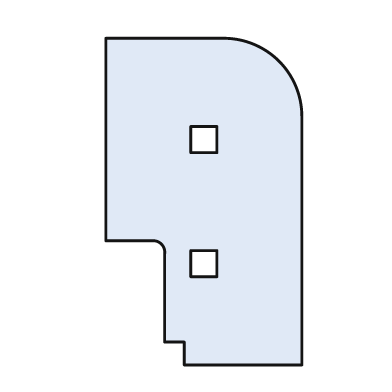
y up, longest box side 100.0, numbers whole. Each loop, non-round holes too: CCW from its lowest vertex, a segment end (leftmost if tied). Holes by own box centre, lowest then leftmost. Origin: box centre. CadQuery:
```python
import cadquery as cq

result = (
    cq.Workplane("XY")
    .moveTo(-6.0, -50.0)
    .lineTo(30.0, -50.0)
    .lineTo(30.0, 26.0)
    .threePointArc((23.0, 43.0), (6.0, 50.0))
    .lineTo(-30.0, 50.0)
    .lineTo(-30.0, -12.0)
    .lineTo(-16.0, -12.0)
    .threePointArc((-13.0, -13.0), (-12.0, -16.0))
    .lineTo(-12.0, -43.0)
    .lineTo(-6.0, -43.0)
    .close()
    .moveTo(-4.0, -23.0)
    .lineTo(4.0, -23.0)
    .lineTo(4.0, -15.0)
    .lineTo(-4.0, -15.0)
    .close()
    .moveTo(-4.0, 15.0)
    .lineTo(4.0, 15.0)
    .lineTo(4.0, 23.0)
    .lineTo(-4.0, 23.0)
    .close()
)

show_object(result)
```